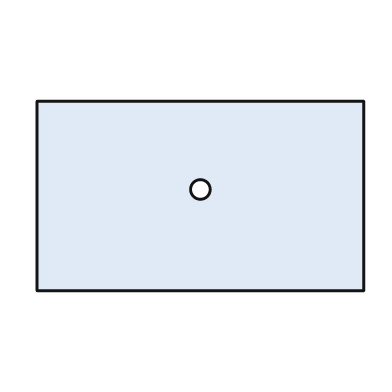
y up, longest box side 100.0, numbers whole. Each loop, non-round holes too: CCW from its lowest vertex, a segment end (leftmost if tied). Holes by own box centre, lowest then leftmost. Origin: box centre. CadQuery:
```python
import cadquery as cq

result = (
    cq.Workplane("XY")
    .moveTo(-50.0, -29.0)
    .lineTo(50.0, -29.0)
    .lineTo(50.0, 29.0)
    .lineTo(-50.0, 29.0)
    .close()
    .moveTo(0.0, 2.0)
    .circle(3.0)
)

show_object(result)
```